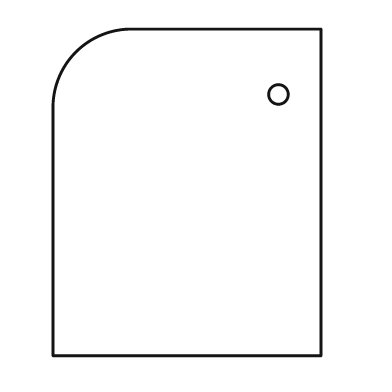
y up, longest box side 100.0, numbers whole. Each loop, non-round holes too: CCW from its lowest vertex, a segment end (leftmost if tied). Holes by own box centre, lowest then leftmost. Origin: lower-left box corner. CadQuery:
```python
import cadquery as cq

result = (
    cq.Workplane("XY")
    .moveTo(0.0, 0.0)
    .lineTo(82.0, 0.0)
    .lineTo(82.0, 100.0)
    .lineTo(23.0, 100.0)
    .threePointArc((7.0, 93.0), (0.0, 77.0))
    .close()
    .moveTo(69.0, 80.0)
    .circle(3.0)
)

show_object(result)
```